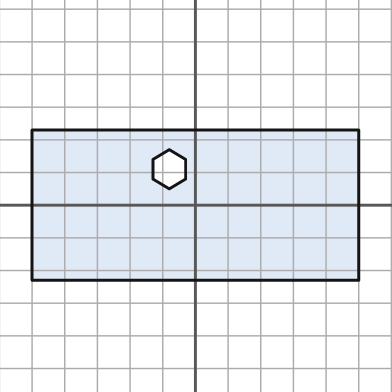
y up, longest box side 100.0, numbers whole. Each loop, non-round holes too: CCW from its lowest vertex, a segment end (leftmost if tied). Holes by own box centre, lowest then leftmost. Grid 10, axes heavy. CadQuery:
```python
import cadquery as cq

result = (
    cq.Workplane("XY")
    .moveTo(-50.0, -23.0)
    .lineTo(50.0, -23.0)
    .lineTo(50.0, 23.0)
    .lineTo(-50.0, 23.0)
    .close()
    .moveTo(-8.0, 5.0)
    .lineTo(-3.0, 8.0)
    .lineTo(-3.0, 14.0)
    .lineTo(-8.0, 17.0)
    .lineTo(-13.0, 14.0)
    .lineTo(-13.0, 8.0)
    .close()
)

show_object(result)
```